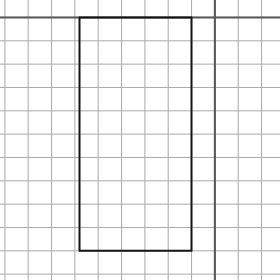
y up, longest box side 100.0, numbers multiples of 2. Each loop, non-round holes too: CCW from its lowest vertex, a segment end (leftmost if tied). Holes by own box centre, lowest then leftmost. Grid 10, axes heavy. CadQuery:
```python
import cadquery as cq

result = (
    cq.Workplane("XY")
    .moveTo(-58.0, -100.0)
    .lineTo(-10.0, -100.0)
    .lineTo(-10.0, 0.0)
    .lineTo(-58.0, 0.0)
    .close()
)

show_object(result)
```